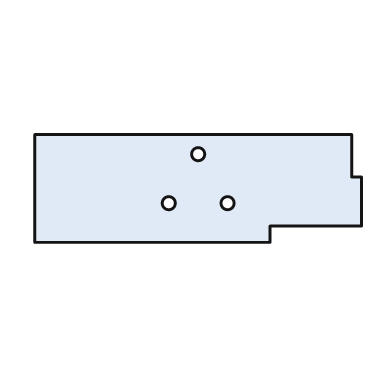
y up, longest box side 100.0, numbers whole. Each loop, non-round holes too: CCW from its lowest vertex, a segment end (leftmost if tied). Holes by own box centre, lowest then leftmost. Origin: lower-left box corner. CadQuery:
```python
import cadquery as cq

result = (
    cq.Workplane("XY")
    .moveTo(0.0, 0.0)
    .lineTo(72.0, 0.0)
    .lineTo(72.0, 5.0)
    .lineTo(100.0, 5.0)
    .lineTo(100.0, 20.0)
    .lineTo(97.0, 20.0)
    .lineTo(97.0, 33.0)
    .lineTo(0.0, 33.0)
    .close()
    .moveTo(41.0, 12.0)
    .circle(2.0)
    .moveTo(59.0, 12.0)
    .circle(2.0)
    .moveTo(50.0, 27.0)
    .circle(2.0)
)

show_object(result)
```